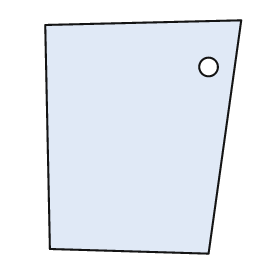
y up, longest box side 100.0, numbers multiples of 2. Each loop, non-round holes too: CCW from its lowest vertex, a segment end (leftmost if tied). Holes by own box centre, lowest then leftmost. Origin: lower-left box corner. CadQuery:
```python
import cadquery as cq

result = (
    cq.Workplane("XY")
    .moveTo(70.0, 0.0)
    .lineTo(84.0, 100.0)
    .lineTo(0.0, 98.0)
    .lineTo(2.0, 2.0)
    .close()
    .moveTo(70.0, 80.0)
    .circle(4.0)
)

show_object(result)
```